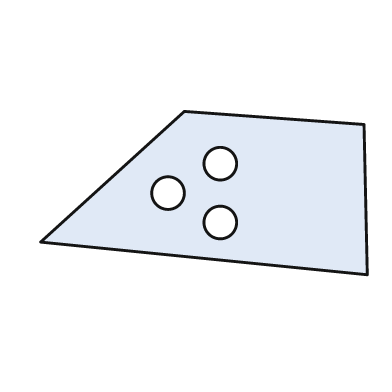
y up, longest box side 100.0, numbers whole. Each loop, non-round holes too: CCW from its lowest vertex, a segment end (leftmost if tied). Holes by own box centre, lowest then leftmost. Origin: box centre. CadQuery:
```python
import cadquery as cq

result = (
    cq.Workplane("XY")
    .moveTo(50.0, -25.0)
    .lineTo(49.0, 21.0)
    .lineTo(-6.0, 25.0)
    .lineTo(-50.0, -15.0)
    .close()
    .moveTo(5.0, -9.0)
    .circle(5.0)
    .moveTo(-11.0, 0.0)
    .circle(5.0)
    .moveTo(5.0, 9.0)
    .circle(5.0)
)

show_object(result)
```